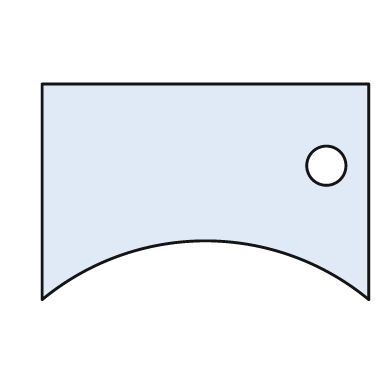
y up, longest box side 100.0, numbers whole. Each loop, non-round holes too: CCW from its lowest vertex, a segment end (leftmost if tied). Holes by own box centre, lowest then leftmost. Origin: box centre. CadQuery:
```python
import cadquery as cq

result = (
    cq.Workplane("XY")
    .moveTo(-50.0, -33.0)
    .threePointArc((0.0, -15.0), (50.0, -33.0))
    .lineTo(50.0, 33.0)
    .lineTo(-50.0, 33.0)
    .close()
    .moveTo(37.0, 8.0)
    .circle(6.0)
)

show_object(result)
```